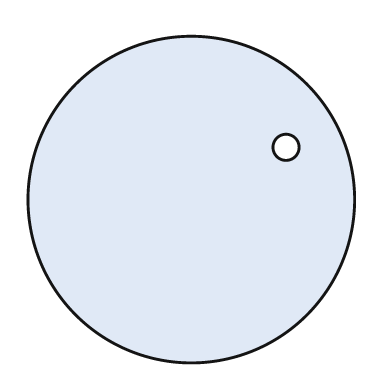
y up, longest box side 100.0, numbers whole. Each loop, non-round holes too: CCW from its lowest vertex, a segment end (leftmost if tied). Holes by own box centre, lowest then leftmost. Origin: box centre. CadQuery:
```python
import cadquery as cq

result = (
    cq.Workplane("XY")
    .moveTo(0.0, 0.0)
    .circle(50.0)
    .moveTo(29.0, 16.0)
    .circle(4.0)
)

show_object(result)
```